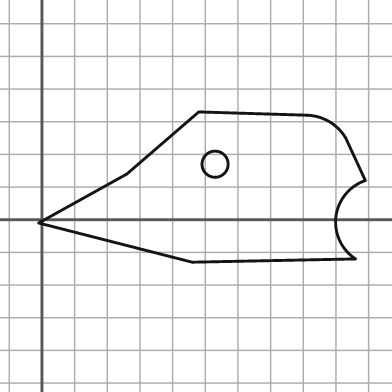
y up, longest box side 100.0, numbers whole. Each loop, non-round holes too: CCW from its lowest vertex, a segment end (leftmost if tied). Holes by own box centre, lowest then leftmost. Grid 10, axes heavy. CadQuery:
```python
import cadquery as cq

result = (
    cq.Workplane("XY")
    .moveTo(46.0, -13.0)
    .lineTo(96.0, -12.0)
    .threePointArc((90.0, 1.0), (99.0, 12.0))
    .lineTo(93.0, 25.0)
    .threePointArc((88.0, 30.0), (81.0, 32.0))
    .lineTo(48.0, 33.0)
    .lineTo(26.0, 14.0)
    .lineTo(-1.0, -1.0)
    .close()
    .moveTo(53.0, 17.0)
    .circle(4.0)
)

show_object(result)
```